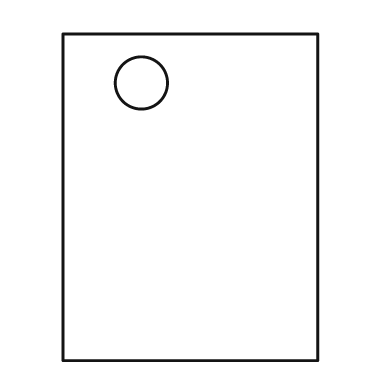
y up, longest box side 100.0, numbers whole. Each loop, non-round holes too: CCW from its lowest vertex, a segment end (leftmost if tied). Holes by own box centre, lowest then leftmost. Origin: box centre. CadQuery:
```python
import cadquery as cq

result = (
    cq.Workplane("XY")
    .moveTo(-39.0, -50.0)
    .lineTo(39.0, -50.0)
    .lineTo(39.0, 50.0)
    .lineTo(-39.0, 50.0)
    .close()
    .moveTo(-15.0, 35.0)
    .circle(8.0)
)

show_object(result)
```